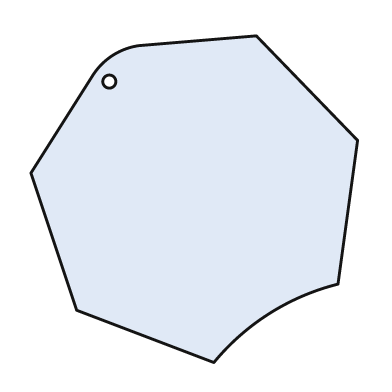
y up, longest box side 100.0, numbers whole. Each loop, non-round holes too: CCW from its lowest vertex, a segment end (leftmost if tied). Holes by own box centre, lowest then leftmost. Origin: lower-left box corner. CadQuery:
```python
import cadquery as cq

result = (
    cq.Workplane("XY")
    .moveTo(56.0, 0.0)
    .threePointArc((73.0, 15.0), (94.0, 24.0))
    .lineTo(100.0, 68.0)
    .lineTo(69.0, 100.0)
    .lineTo(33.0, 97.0)
    .threePointArc((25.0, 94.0), (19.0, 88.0))
    .lineTo(0.0, 58.0)
    .lineTo(14.0, 16.0)
    .close()
    .moveTo(24.0, 86.0)
    .circle(2.0)
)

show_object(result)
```